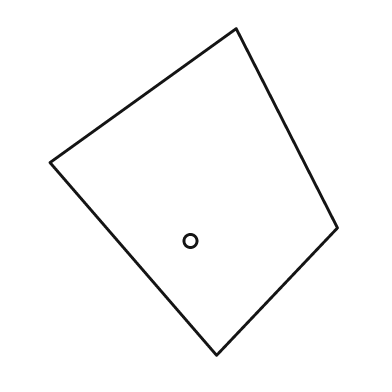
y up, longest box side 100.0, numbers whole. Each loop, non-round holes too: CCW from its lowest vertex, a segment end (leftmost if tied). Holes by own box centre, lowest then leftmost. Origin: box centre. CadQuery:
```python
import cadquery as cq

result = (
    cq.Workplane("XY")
    .moveTo(7.0, -50.0)
    .lineTo(44.0, -11.0)
    .lineTo(13.0, 50.0)
    .lineTo(-44.0, 9.0)
    .close()
    .moveTo(-1.0, -15.0)
    .circle(2.0)
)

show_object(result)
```